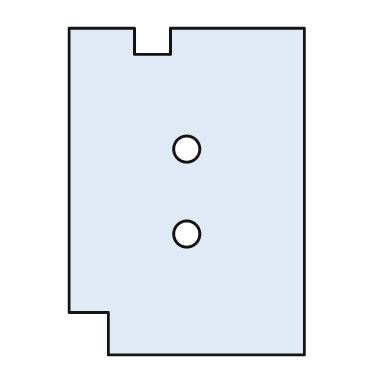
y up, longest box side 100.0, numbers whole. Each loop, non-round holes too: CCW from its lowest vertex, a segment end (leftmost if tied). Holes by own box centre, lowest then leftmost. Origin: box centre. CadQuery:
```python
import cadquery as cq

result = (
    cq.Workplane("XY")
    .moveTo(-24.0, -50.0)
    .lineTo(36.0, -50.0)
    .lineTo(36.0, 50.0)
    .lineTo(-5.0, 50.0)
    .lineTo(-5.0, 42.0)
    .lineTo(-16.0, 42.0)
    .lineTo(-16.0, 50.0)
    .lineTo(-36.0, 50.0)
    .lineTo(-36.0, -37.0)
    .lineTo(-24.0, -37.0)
    .close()
    .moveTo(0.0, -13.0)
    .circle(4.0)
    .moveTo(0.0, 13.0)
    .circle(4.0)
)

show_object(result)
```